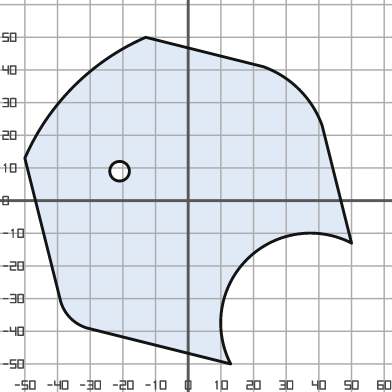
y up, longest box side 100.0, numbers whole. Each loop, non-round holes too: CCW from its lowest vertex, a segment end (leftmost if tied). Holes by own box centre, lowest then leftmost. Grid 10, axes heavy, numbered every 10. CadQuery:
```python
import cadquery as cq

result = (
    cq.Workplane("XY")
    .moveTo(13.0, -50.0)
    .threePointArc((18.0, -18.0), (50.0, -13.0))
    .lineTo(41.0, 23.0)
    .threePointArc((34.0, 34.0), (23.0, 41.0))
    .lineTo(-13.0, 50.0)
    .threePointArc((-35.0, 35.0), (-50.0, 13.0))
    .lineTo(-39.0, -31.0)
    .threePointArc((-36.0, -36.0), (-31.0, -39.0))
    .close()
    .moveTo(-21.0, 9.0)
    .circle(3.0)
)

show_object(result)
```